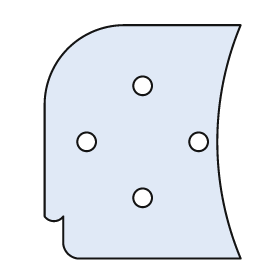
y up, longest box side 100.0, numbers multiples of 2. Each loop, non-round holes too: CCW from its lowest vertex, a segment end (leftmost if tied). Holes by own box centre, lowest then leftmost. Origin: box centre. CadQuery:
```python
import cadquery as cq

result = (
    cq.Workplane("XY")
    .moveTo(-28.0, -50.0)
    .lineTo(42.0, -50.0)
    .threePointArc((32.0, 0.0), (42.0, 50.0))
    .lineTo(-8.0, 50.0)
    .threePointArc((-32.0, 40.0), (-42.0, 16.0))
    .lineTo(-42.0, -32.0)
    .threePointArc((-38.0, -34.0), (-34.0, -32.0))
    .lineTo(-34.0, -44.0)
    .threePointArc((-32.0, -48.0), (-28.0, -50.0))
    .close()
    .moveTo(0.0, -24.0)
    .circle(4.0)
    .moveTo(-24.0, 0.0)
    .circle(4.0)
    .moveTo(24.0, 0.0)
    .circle(4.0)
    .moveTo(0.0, 24.0)
    .circle(4.0)
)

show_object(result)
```